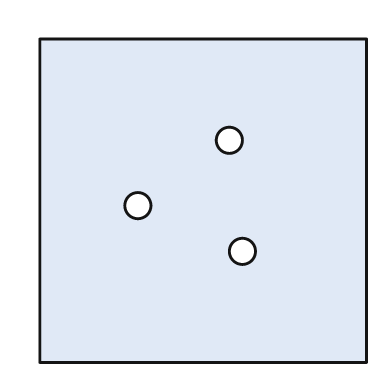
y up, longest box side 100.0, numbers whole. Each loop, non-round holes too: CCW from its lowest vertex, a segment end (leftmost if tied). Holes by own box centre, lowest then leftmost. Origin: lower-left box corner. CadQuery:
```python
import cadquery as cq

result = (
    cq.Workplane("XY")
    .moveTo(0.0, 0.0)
    .lineTo(100.0, 0.0)
    .lineTo(100.0, 99.0)
    .lineTo(0.0, 99.0)
    .close()
    .moveTo(62.0, 34.0)
    .circle(4.0)
    .moveTo(30.0, 48.0)
    .circle(4.0)
    .moveTo(58.0, 68.0)
    .circle(4.0)
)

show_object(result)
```